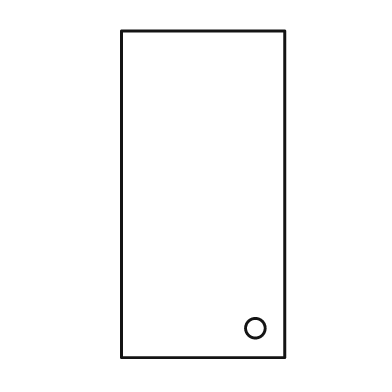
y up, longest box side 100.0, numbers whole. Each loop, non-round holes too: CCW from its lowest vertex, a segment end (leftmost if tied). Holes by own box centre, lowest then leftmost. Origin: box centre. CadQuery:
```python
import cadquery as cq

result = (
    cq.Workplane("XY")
    .moveTo(-25.0, -50.0)
    .lineTo(25.0, -50.0)
    .lineTo(25.0, 50.0)
    .lineTo(-25.0, 50.0)
    .close()
    .moveTo(16.0, -41.0)
    .circle(3.0)
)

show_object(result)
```